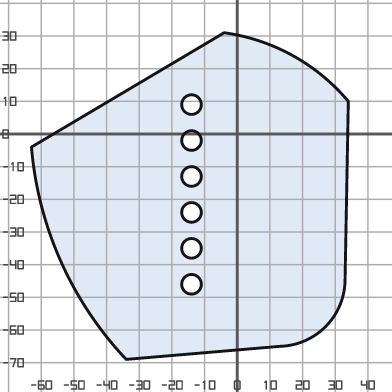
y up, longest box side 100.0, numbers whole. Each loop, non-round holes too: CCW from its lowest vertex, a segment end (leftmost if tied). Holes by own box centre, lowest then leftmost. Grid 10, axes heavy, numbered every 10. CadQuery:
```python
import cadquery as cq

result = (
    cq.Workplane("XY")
    .moveTo(-34.0, -69.0)
    .lineTo(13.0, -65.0)
    .threePointArc((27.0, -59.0), (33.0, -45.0))
    .lineTo(34.0, 10.0)
    .threePointArc((17.0, 24.0), (-4.0, 31.0))
    .lineTo(-63.0, -4.0)
    .threePointArc((-54.0, -39.0), (-34.0, -69.0))
    .close()
    .moveTo(-14.0, -46.0)
    .circle(3.0)
    .moveTo(-14.0, -35.0)
    .circle(3.0)
    .moveTo(-14.0, -24.0)
    .circle(3.0)
    .moveTo(-14.0, -13.0)
    .circle(3.0)
    .moveTo(-14.0, -2.0)
    .circle(3.0)
    .moveTo(-14.0, 9.0)
    .circle(3.0)
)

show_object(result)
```